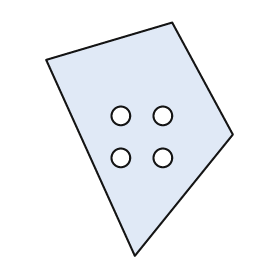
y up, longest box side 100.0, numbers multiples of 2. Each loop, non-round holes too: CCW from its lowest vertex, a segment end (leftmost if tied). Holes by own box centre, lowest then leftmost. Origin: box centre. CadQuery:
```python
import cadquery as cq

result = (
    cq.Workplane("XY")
    .moveTo(-2.0, -50.0)
    .lineTo(40.0, 2.0)
    .lineTo(14.0, 50.0)
    .lineTo(-40.0, 34.0)
    .close()
    .moveTo(-8.0, -8.0)
    .circle(4.0)
    .moveTo(10.0, -8.0)
    .circle(4.0)
    .moveTo(-8.0, 10.0)
    .circle(4.0)
    .moveTo(10.0, 10.0)
    .circle(4.0)
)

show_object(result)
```